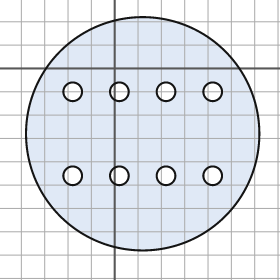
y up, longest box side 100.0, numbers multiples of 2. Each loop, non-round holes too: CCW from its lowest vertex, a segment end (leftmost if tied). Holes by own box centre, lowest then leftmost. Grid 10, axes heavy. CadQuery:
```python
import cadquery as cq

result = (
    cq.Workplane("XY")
    .moveTo(12.0, -28.0)
    .circle(50.0)
    .moveTo(-18.0, -46.0)
    .circle(4.0)
    .moveTo(2.0, -46.0)
    .circle(4.0)
    .moveTo(22.0, -46.0)
    .circle(4.0)
    .moveTo(42.0, -46.0)
    .circle(4.0)
    .moveTo(-18.0, -10.0)
    .circle(4.0)
    .moveTo(2.0, -10.0)
    .circle(4.0)
    .moveTo(22.0, -10.0)
    .circle(4.0)
    .moveTo(42.0, -10.0)
    .circle(4.0)
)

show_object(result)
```